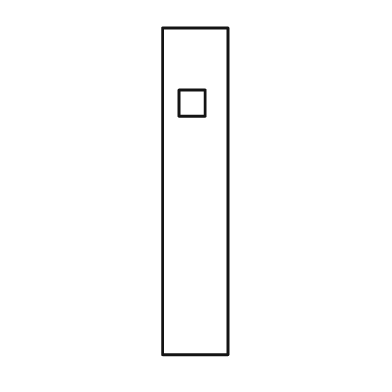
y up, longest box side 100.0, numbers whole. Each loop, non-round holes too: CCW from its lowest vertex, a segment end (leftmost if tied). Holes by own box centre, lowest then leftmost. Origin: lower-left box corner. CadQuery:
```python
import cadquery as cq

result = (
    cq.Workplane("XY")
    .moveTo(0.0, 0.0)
    .lineTo(20.0, 0.0)
    .lineTo(20.0, 100.0)
    .lineTo(0.0, 100.0)
    .close()
    .moveTo(5.0, 73.0)
    .lineTo(13.0, 73.0)
    .lineTo(13.0, 81.0)
    .lineTo(5.0, 81.0)
    .close()
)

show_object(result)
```